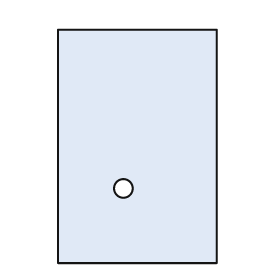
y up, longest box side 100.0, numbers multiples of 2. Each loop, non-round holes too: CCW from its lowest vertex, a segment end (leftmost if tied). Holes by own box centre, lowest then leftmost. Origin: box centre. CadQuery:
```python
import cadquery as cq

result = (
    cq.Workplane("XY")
    .moveTo(-34.0, -50.0)
    .lineTo(34.0, -50.0)
    .lineTo(34.0, 50.0)
    .lineTo(-34.0, 50.0)
    .close()
    .moveTo(-6.0, -18.0)
    .circle(4.0)
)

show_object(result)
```